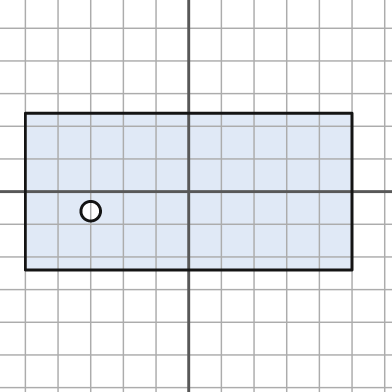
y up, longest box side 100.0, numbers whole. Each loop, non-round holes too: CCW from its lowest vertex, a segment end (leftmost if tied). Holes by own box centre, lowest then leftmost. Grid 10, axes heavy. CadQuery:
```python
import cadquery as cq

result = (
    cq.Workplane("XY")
    .moveTo(-50.0, -24.0)
    .lineTo(50.0, -24.0)
    .lineTo(50.0, 24.0)
    .lineTo(-50.0, 24.0)
    .close()
    .moveTo(-30.0, -6.0)
    .circle(3.0)
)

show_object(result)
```